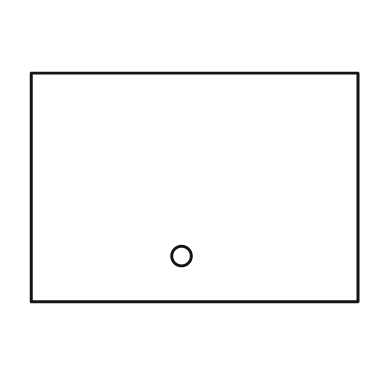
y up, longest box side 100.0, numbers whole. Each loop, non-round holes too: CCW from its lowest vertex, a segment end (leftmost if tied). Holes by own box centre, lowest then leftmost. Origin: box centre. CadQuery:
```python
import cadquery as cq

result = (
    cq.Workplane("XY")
    .moveTo(-50.0, -35.0)
    .lineTo(50.0, -35.0)
    .lineTo(50.0, 35.0)
    .lineTo(-50.0, 35.0)
    .close()
    .moveTo(-4.0, -21.0)
    .circle(3.0)
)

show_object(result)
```